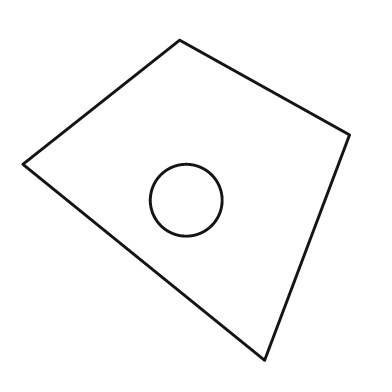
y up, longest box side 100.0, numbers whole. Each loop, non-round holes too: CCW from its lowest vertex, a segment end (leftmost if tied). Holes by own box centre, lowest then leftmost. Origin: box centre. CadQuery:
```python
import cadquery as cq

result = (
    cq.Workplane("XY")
    .moveTo(24.0, -49.0)
    .lineTo(50.0, 20.0)
    .lineTo(-2.0, 49.0)
    .lineTo(-50.0, 11.0)
    .close()
    .moveTo(0.0, 0.0)
    .circle(11.0)
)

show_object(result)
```